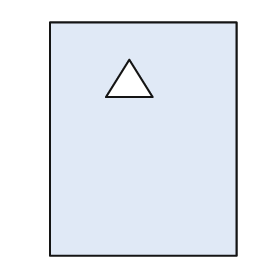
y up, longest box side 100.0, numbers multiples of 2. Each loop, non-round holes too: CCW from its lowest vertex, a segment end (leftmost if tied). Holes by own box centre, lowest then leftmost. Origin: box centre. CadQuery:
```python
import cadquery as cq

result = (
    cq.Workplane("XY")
    .moveTo(-40.0, -50.0)
    .lineTo(40.0, -50.0)
    .lineTo(40.0, 50.0)
    .lineTo(-40.0, 50.0)
    .close()
    .moveTo(-16.0, 18.0)
    .lineTo(4.0, 18.0)
    .lineTo(-6.0, 34.0)
    .close()
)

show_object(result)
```